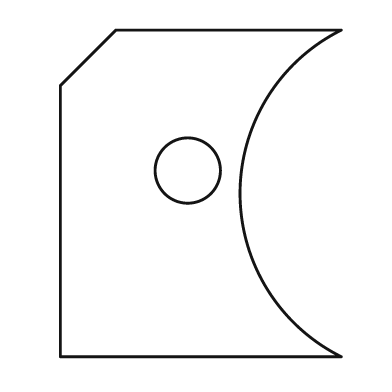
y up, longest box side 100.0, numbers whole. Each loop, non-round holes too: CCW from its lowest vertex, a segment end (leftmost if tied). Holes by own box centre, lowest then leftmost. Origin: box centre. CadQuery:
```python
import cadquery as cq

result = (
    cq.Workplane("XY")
    .moveTo(-43.0, -50.0)
    .lineTo(43.0, -50.0)
    .threePointArc((12.0, 0.0), (43.0, 50.0))
    .lineTo(-26.0, 50.0)
    .lineTo(-43.0, 33.0)
    .close()
    .moveTo(-4.0, 7.0)
    .circle(10.0)
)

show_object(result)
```